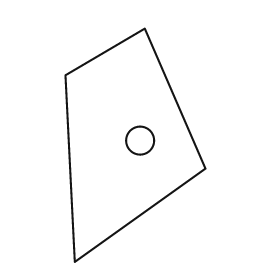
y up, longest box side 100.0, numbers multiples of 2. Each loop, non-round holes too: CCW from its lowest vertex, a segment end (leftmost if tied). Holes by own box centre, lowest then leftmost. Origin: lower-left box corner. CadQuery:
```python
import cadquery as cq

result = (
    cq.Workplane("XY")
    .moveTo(4.0, 0.0)
    .lineTo(60.0, 40.0)
    .lineTo(34.0, 100.0)
    .lineTo(0.0, 80.0)
    .close()
    .moveTo(32.0, 52.0)
    .circle(6.0)
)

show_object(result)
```